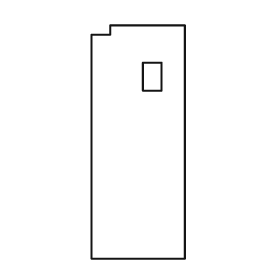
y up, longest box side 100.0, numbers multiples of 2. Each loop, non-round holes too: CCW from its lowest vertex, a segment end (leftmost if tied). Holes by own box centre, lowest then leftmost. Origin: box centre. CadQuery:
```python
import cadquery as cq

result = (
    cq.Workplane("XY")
    .moveTo(-20.0, -50.0)
    .lineTo(20.0, -50.0)
    .lineTo(20.0, 50.0)
    .lineTo(-12.0, 50.0)
    .lineTo(-12.0, 46.0)
    .lineTo(-20.0, 46.0)
    .close()
    .moveTo(2.0, 22.0)
    .lineTo(10.0, 22.0)
    .lineTo(10.0, 34.0)
    .lineTo(2.0, 34.0)
    .close()
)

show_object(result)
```